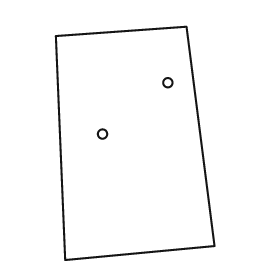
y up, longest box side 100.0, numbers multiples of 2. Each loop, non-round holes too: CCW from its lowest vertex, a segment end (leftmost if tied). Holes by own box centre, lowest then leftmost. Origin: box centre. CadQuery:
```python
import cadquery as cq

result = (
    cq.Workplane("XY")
    .moveTo(-30.0, -50.0)
    .lineTo(34.0, -44.0)
    .lineTo(22.0, 50.0)
    .lineTo(-34.0, 46.0)
    .close()
    .moveTo(-14.0, 4.0)
    .circle(2.0)
    .moveTo(14.0, 26.0)
    .circle(2.0)
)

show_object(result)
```